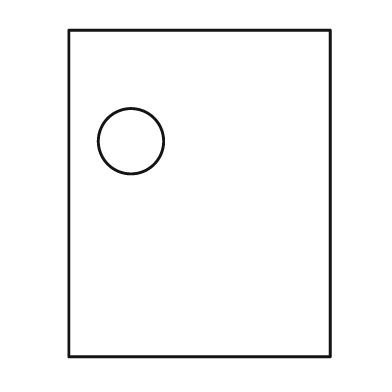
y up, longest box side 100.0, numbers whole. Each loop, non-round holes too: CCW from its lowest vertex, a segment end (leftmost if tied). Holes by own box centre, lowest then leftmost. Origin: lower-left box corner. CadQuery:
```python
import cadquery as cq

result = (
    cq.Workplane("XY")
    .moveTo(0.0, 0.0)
    .lineTo(80.0, 0.0)
    .lineTo(80.0, 100.0)
    .lineTo(0.0, 100.0)
    .close()
    .moveTo(19.0, 66.0)
    .circle(10.0)
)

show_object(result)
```